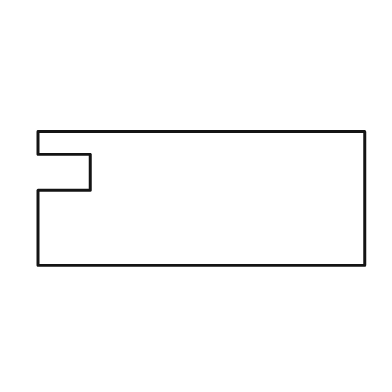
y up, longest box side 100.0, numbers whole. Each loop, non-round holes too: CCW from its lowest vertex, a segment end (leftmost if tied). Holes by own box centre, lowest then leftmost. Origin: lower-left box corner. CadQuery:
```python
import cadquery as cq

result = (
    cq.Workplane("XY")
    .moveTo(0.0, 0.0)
    .lineTo(100.0, 0.0)
    .lineTo(100.0, 41.0)
    .lineTo(0.0, 41.0)
    .lineTo(0.0, 34.0)
    .lineTo(16.0, 34.0)
    .lineTo(16.0, 23.0)
    .lineTo(0.0, 23.0)
    .close()
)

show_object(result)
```